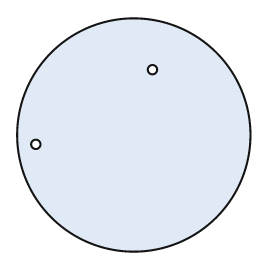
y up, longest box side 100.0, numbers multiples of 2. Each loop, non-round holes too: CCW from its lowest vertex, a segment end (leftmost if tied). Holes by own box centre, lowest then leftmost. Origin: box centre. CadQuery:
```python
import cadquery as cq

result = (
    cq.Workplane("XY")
    .moveTo(0.0, 0.0)
    .circle(50.0)
    .moveTo(-42.0, -4.0)
    .circle(2.0)
    .moveTo(8.0, 28.0)
    .circle(2.0)
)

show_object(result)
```